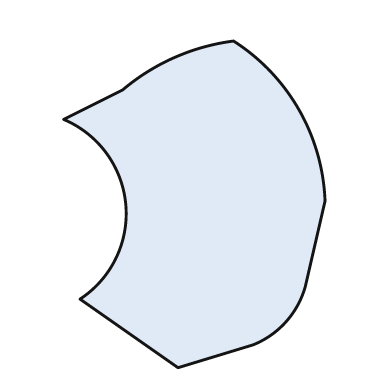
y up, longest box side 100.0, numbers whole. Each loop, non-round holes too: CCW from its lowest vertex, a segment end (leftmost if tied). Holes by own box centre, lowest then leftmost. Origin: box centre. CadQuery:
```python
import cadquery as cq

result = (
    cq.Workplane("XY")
    .moveTo(-5.0, -50.0)
    .lineTo(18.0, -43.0)
    .threePointArc((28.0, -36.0), (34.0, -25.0))
    .lineTo(40.0, 1.0)
    .threePointArc((32.0, 29.0), (12.0, 50.0))
    .threePointArc((-6.0, 45.0), (-22.0, 35.0))
    .lineTo(-40.0, 26.0)
    .threePointArc((-21.0, 0.0), (-35.0, -29.0))
    .close()
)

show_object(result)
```